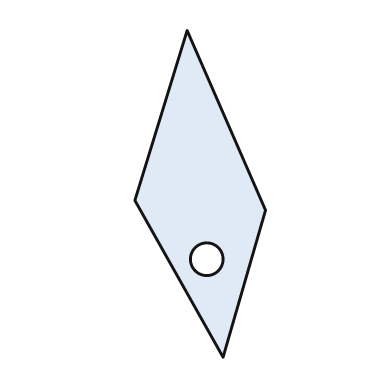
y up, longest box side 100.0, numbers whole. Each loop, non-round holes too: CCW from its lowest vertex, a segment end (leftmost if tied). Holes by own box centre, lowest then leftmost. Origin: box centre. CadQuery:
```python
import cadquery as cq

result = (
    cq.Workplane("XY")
    .moveTo(7.0, -50.0)
    .lineTo(20.0, -5.0)
    .lineTo(-4.0, 50.0)
    .lineTo(-20.0, -2.0)
    .close()
    .moveTo(2.0, -20.0)
    .circle(5.0)
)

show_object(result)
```